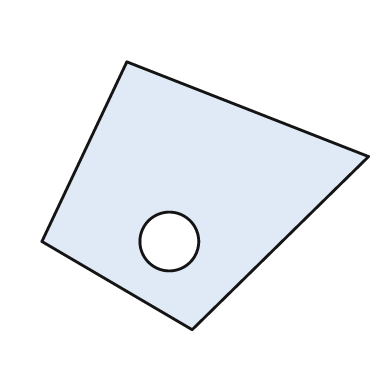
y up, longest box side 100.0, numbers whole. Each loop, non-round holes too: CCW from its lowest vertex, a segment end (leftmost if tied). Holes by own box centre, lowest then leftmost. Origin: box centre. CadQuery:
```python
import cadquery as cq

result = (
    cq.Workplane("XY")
    .moveTo(-4.0, -41.0)
    .lineTo(50.0, 12.0)
    .lineTo(-24.0, 41.0)
    .lineTo(-50.0, -14.0)
    .close()
    .moveTo(-11.0, -14.0)
    .circle(9.0)
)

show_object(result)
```